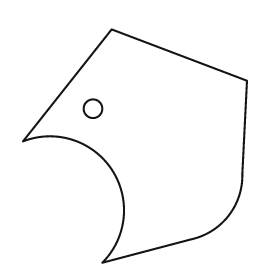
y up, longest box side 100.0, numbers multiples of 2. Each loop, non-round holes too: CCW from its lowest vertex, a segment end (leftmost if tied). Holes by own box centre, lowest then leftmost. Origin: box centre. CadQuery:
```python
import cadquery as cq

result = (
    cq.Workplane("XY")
    .moveTo(-14.0, -50.0)
    .lineTo(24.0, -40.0)
    .threePointArc((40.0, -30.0), (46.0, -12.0))
    .lineTo(48.0, 28.0)
    .lineTo(-10.0, 50.0)
    .lineTo(-48.0, 2.0)
    .threePointArc((-10.0, -10.0), (-14.0, -50.0))
    .close()
    .moveTo(-18.0, 16.0)
    .circle(4.0)
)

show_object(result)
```